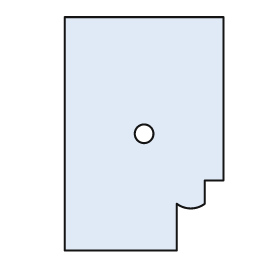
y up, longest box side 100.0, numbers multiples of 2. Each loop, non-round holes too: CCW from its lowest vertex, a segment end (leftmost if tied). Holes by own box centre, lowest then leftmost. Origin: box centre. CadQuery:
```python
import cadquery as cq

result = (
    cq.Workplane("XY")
    .moveTo(-34.0, -50.0)
    .lineTo(14.0, -50.0)
    .lineTo(14.0, -30.0)
    .threePointArc((20.0, -32.0), (26.0, -30.0))
    .lineTo(26.0, -20.0)
    .lineTo(34.0, -20.0)
    .lineTo(34.0, 50.0)
    .lineTo(-34.0, 50.0)
    .close()
    .moveTo(0.0, 0.0)
    .circle(4.0)
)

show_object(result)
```